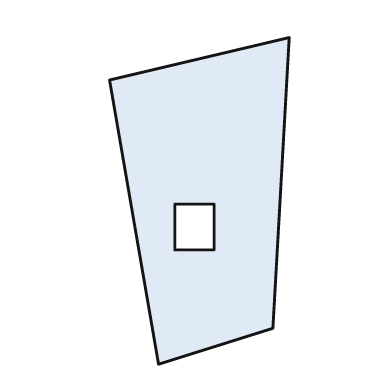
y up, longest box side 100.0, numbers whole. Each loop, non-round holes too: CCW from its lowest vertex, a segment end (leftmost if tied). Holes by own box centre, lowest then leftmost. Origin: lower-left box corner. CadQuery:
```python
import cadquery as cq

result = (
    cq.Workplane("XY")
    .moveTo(15.0, 0.0)
    .lineTo(50.0, 11.0)
    .lineTo(55.0, 100.0)
    .lineTo(0.0, 87.0)
    .close()
    .moveTo(20.0, 35.0)
    .lineTo(32.0, 35.0)
    .lineTo(32.0, 49.0)
    .lineTo(20.0, 49.0)
    .close()
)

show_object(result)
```